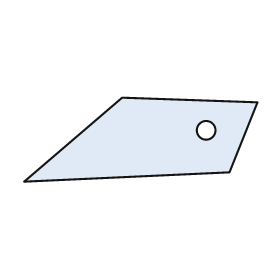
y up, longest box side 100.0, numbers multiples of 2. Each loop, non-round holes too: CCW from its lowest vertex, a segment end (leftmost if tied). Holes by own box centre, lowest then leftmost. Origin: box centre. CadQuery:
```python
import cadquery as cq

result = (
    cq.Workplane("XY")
    .moveTo(-50.0, -18.0)
    .lineTo(38.0, -14.0)
    .lineTo(50.0, 16.0)
    .lineTo(-8.0, 18.0)
    .close()
    .moveTo(28.0, 4.0)
    .circle(4.0)
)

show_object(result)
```